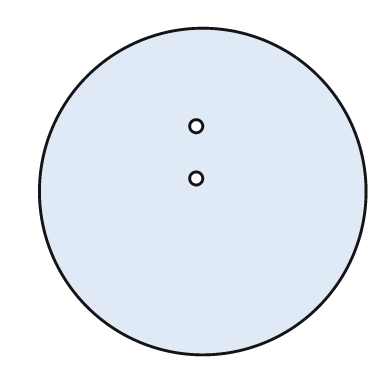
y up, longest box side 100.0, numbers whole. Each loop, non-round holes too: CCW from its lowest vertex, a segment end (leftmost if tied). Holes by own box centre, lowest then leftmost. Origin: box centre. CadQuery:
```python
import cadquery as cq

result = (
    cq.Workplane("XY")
    .moveTo(0.0, 0.0)
    .circle(50.0)
    .moveTo(-2.0, 4.0)
    .circle(2.0)
    .moveTo(-2.0, 20.0)
    .circle(2.0)
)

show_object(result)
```